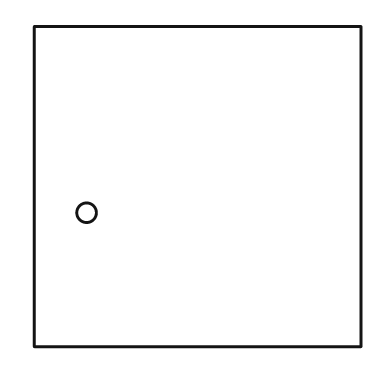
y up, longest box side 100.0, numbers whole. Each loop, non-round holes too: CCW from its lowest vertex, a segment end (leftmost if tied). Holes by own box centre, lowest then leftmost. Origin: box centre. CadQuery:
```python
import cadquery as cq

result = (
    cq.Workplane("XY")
    .moveTo(-50.0, -49.0)
    .lineTo(50.0, -49.0)
    .lineTo(50.0, 49.0)
    .lineTo(-50.0, 49.0)
    .close()
    .moveTo(-34.0, -8.0)
    .circle(3.0)
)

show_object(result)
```